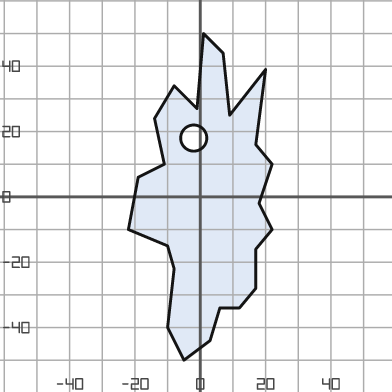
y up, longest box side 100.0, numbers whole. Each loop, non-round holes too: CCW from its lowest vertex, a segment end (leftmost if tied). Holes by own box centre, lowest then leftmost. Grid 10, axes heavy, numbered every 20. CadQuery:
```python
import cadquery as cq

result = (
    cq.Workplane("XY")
    .moveTo(-5.0, -50.0)
    .lineTo(3.0, -44.0)
    .lineTo(6.0, -34.0)
    .lineTo(12.0, -34.0)
    .lineTo(17.0, -28.0)
    .lineTo(17.0, -16.0)
    .lineTo(22.0, -10.0)
    .lineTo(18.0, -2.0)
    .lineTo(22.0, 10.0)
    .lineTo(17.0, 16.0)
    .lineTo(20.0, 39.0)
    .lineTo(9.0, 25.0)
    .lineTo(7.0, 44.0)
    .lineTo(1.0, 50.0)
    .lineTo(-1.0, 27.0)
    .lineTo(-8.0, 34.0)
    .lineTo(-14.0, 24.0)
    .lineTo(-11.0, 10.0)
    .lineTo(-19.0, 6.0)
    .lineTo(-22.0, -10.0)
    .lineTo(-10.0, -15.0)
    .lineTo(-8.0, -22.0)
    .lineTo(-10.0, -40.0)
    .close()
    .moveTo(-2.0, 18.0)
    .circle(4.0)
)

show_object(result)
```